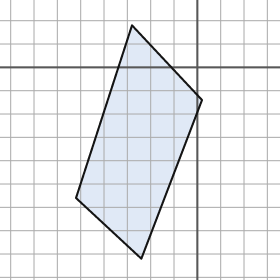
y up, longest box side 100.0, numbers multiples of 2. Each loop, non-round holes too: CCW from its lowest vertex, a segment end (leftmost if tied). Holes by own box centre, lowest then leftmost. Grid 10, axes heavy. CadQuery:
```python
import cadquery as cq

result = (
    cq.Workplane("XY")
    .moveTo(-24.0, -82.0)
    .lineTo(2.0, -14.0)
    .lineTo(-28.0, 18.0)
    .lineTo(-52.0, -56.0)
    .close()
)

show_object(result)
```